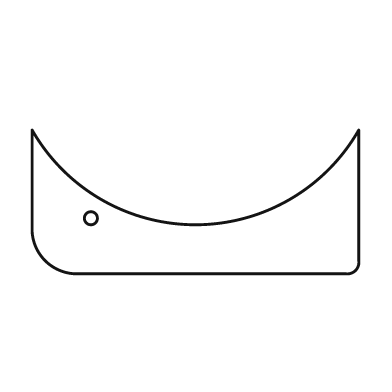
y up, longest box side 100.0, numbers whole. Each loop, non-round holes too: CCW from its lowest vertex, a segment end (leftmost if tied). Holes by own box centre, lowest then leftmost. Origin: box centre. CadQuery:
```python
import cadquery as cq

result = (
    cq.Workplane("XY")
    .moveTo(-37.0, -22.0)
    .lineTo(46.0, -22.0)
    .threePointArc((49.0, -21.0), (50.0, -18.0))
    .lineTo(50.0, 22.0)
    .threePointArc((0.0, -7.0), (-50.0, 22.0))
    .lineTo(-50.0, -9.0)
    .threePointArc((-46.0, -18.0), (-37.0, -22.0))
    .close()
    .moveTo(-32.0, -5.0)
    .circle(2.0)
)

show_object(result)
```